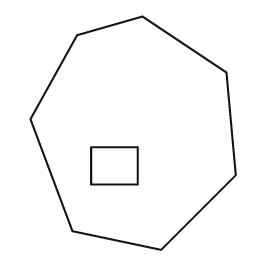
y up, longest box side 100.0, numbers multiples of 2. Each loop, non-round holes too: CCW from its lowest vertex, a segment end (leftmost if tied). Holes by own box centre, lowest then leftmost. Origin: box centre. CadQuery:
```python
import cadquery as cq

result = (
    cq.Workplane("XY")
    .moveTo(12.0, -50.0)
    .lineTo(44.0, -18.0)
    .lineTo(40.0, 26.0)
    .lineTo(4.0, 50.0)
    .lineTo(-24.0, 42.0)
    .lineTo(-44.0, 6.0)
    .lineTo(-26.0, -42.0)
    .close()
    .moveTo(-18.0, -22.0)
    .lineTo(2.0, -22.0)
    .lineTo(2.0, -6.0)
    .lineTo(-18.0, -6.0)
    .close()
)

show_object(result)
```